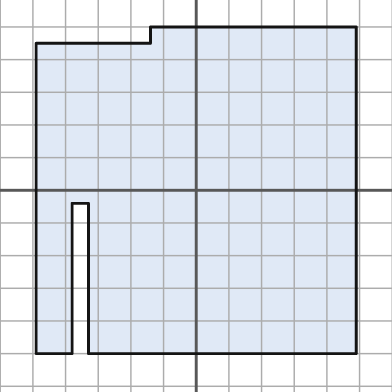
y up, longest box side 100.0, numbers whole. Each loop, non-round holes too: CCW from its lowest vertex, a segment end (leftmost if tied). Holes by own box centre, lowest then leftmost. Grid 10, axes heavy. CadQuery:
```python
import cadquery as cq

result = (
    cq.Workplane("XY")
    .moveTo(-49.0, -50.0)
    .lineTo(-38.0, -50.0)
    .lineTo(-38.0, -4.0)
    .lineTo(-33.0, -4.0)
    .lineTo(-33.0, -50.0)
    .lineTo(49.0, -50.0)
    .lineTo(49.0, 50.0)
    .lineTo(-14.0, 50.0)
    .lineTo(-14.0, 45.0)
    .lineTo(-49.0, 45.0)
    .close()
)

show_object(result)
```